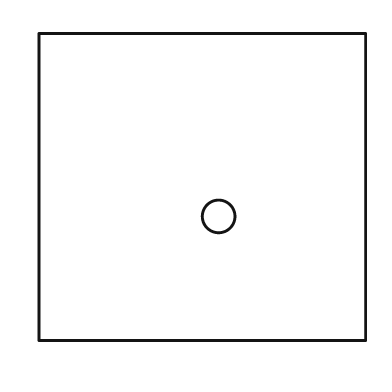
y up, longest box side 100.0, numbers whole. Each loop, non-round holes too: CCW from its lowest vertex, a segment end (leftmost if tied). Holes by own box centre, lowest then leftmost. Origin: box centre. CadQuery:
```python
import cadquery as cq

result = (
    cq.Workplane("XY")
    .moveTo(-50.0, -47.0)
    .lineTo(50.0, -47.0)
    .lineTo(50.0, 47.0)
    .lineTo(-50.0, 47.0)
    .close()
    .moveTo(5.0, -9.0)
    .circle(5.0)
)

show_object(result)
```